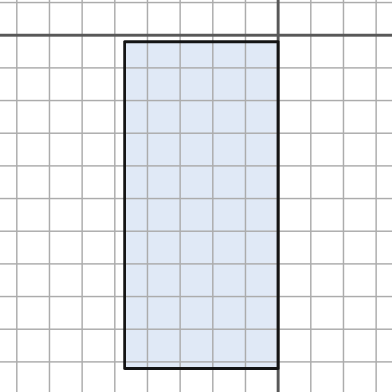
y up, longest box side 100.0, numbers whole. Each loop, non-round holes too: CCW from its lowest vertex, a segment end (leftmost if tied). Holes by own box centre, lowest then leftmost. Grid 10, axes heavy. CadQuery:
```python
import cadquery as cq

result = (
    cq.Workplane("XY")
    .moveTo(-47.0, -102.0)
    .lineTo(0.0, -102.0)
    .lineTo(0.0, -2.0)
    .lineTo(-47.0, -2.0)
    .close()
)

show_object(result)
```